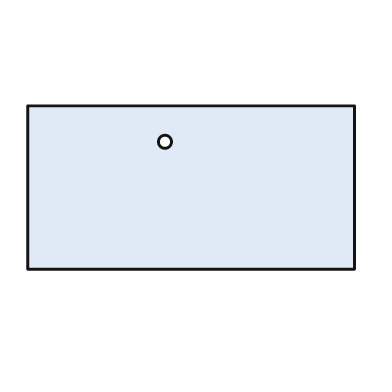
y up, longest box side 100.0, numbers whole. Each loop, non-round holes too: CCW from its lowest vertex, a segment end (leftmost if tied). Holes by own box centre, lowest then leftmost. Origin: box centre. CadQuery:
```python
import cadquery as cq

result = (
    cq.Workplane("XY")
    .moveTo(-50.0, -25.0)
    .lineTo(50.0, -25.0)
    .lineTo(50.0, 25.0)
    .lineTo(-50.0, 25.0)
    .close()
    .moveTo(-8.0, 14.0)
    .circle(2.0)
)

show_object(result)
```